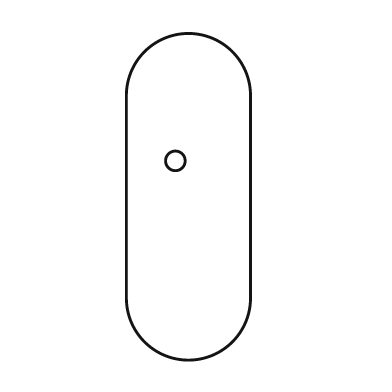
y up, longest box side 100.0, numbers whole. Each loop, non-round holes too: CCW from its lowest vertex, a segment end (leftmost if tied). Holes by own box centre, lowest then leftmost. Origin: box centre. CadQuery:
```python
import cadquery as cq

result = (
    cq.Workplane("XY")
    .moveTo(-19.0, -31.0)
    .threePointArc((0.0, -50.0), (19.0, -31.0))
    .lineTo(19.0, 31.0)
    .threePointArc((0.0, 50.0), (-19.0, 31.0))
    .close()
    .moveTo(-4.0, 11.0)
    .circle(3.0)
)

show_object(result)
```